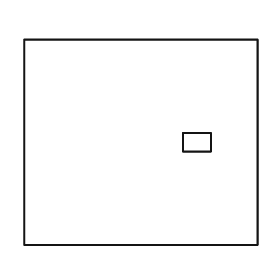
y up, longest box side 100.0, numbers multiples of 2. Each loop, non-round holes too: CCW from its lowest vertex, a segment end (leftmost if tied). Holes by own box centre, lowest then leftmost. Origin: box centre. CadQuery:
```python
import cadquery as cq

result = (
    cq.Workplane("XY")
    .moveTo(-50.0, -44.0)
    .lineTo(50.0, -44.0)
    .lineTo(50.0, 44.0)
    .lineTo(-50.0, 44.0)
    .close()
    .moveTo(18.0, -4.0)
    .lineTo(30.0, -4.0)
    .lineTo(30.0, 4.0)
    .lineTo(18.0, 4.0)
    .close()
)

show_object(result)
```